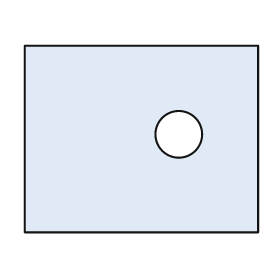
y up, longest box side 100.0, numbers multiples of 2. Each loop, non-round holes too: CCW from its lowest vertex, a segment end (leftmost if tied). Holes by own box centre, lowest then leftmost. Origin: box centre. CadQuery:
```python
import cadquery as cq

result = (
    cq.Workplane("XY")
    .moveTo(-50.0, -40.0)
    .lineTo(50.0, -40.0)
    .lineTo(50.0, 40.0)
    .lineTo(-50.0, 40.0)
    .close()
    .moveTo(16.0, 2.0)
    .circle(10.0)
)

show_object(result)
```